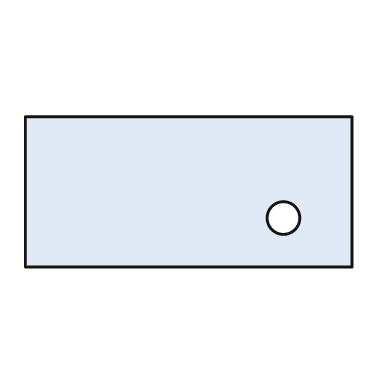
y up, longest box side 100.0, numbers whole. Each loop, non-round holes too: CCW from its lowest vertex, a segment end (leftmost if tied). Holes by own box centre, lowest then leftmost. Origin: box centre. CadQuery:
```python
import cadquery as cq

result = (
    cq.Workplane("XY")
    .moveTo(-50.0, -23.0)
    .lineTo(50.0, -23.0)
    .lineTo(50.0, 23.0)
    .lineTo(-50.0, 23.0)
    .close()
    .moveTo(29.0, -8.0)
    .circle(5.0)
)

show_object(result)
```